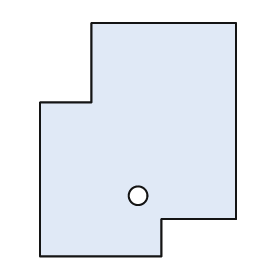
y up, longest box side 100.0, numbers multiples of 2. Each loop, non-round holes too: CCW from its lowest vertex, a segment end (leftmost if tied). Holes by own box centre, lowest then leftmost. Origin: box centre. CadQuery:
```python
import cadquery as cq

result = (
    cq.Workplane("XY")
    .moveTo(-42.0, -50.0)
    .lineTo(10.0, -50.0)
    .lineTo(10.0, -34.0)
    .lineTo(42.0, -34.0)
    .lineTo(42.0, 50.0)
    .lineTo(-20.0, 50.0)
    .lineTo(-20.0, 16.0)
    .lineTo(-42.0, 16.0)
    .close()
    .moveTo(0.0, -24.0)
    .circle(4.0)
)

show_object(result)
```